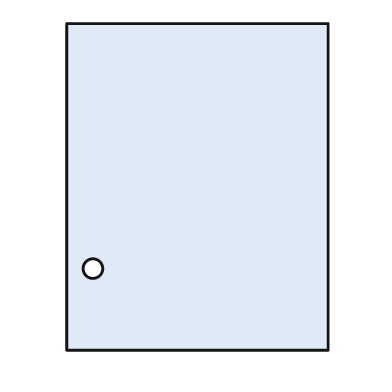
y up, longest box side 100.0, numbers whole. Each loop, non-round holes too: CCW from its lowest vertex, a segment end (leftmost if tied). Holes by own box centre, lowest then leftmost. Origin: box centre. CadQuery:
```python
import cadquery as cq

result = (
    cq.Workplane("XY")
    .moveTo(-40.0, -50.0)
    .lineTo(40.0, -50.0)
    .lineTo(40.0, 50.0)
    .lineTo(-40.0, 50.0)
    .close()
    .moveTo(-32.0, -25.0)
    .circle(3.0)
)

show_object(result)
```